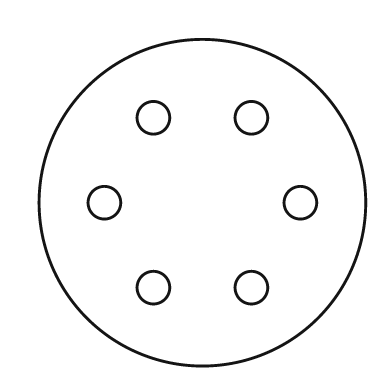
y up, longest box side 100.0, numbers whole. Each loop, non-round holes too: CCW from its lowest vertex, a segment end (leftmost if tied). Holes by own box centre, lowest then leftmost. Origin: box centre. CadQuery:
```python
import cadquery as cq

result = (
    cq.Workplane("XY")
    .moveTo(0.0, 0.0)
    .circle(50.0)
    .moveTo(-15.0, -26.0)
    .circle(5.0)
    .moveTo(15.0, -26.0)
    .circle(5.0)
    .moveTo(-30.0, 0.0)
    .circle(5.0)
    .moveTo(30.0, 0.0)
    .circle(5.0)
    .moveTo(-15.0, 26.0)
    .circle(5.0)
    .moveTo(15.0, 26.0)
    .circle(5.0)
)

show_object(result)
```